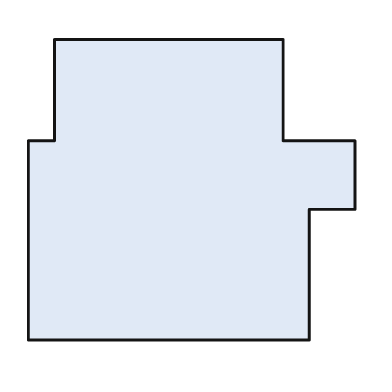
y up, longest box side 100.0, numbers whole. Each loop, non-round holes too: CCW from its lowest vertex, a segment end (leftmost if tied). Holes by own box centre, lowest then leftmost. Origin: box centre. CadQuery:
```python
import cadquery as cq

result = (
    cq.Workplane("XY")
    .moveTo(-50.0, -46.0)
    .lineTo(36.0, -46.0)
    .lineTo(36.0, -6.0)
    .lineTo(50.0, -6.0)
    .lineTo(50.0, 15.0)
    .lineTo(28.0, 15.0)
    .lineTo(28.0, 46.0)
    .lineTo(-42.0, 46.0)
    .lineTo(-42.0, 15.0)
    .lineTo(-50.0, 15.0)
    .close()
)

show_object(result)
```